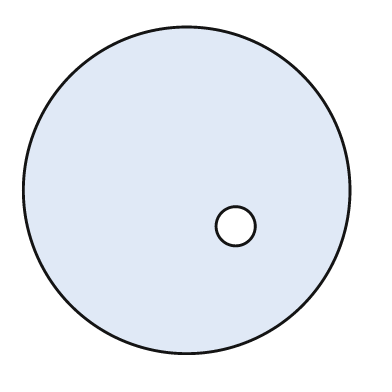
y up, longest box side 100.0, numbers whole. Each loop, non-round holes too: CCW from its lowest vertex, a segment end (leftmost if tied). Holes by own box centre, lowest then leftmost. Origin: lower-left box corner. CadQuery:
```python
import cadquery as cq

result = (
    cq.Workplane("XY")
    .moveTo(50.0, 50.0)
    .circle(50.0)
    .moveTo(65.0, 39.0)
    .circle(6.0)
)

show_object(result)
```